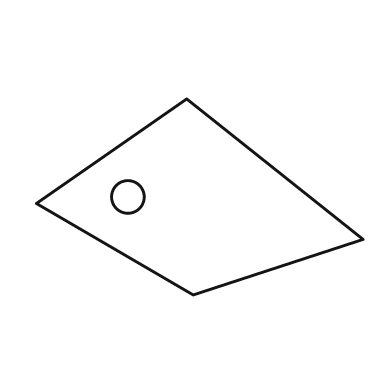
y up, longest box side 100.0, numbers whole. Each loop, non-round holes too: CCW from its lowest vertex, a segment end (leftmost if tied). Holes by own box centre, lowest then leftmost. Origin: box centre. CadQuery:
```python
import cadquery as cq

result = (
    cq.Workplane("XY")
    .moveTo(-2.0, -30.0)
    .lineTo(50.0, -13.0)
    .lineTo(-4.0, 30.0)
    .lineTo(-50.0, -2.0)
    .close()
    .moveTo(-22.0, 0.0)
    .circle(5.0)
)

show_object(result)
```